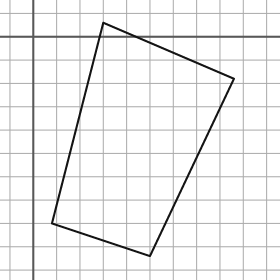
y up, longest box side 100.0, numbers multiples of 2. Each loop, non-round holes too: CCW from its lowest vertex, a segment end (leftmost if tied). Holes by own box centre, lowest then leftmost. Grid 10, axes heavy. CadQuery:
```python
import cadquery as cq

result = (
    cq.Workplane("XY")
    .moveTo(50.0, -94.0)
    .lineTo(86.0, -18.0)
    .lineTo(30.0, 6.0)
    .lineTo(8.0, -80.0)
    .close()
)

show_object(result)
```